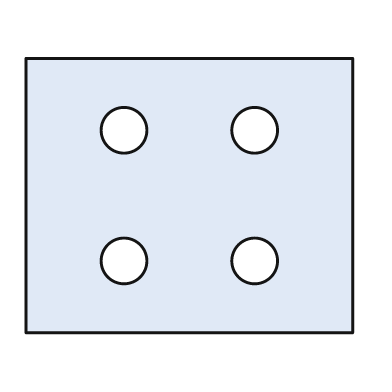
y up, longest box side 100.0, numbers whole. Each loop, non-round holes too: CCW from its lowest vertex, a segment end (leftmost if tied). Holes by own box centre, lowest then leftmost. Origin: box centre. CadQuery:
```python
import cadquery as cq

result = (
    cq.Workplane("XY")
    .moveTo(-50.0, -42.0)
    .lineTo(50.0, -42.0)
    .lineTo(50.0, 42.0)
    .lineTo(-50.0, 42.0)
    .close()
    .moveTo(-20.0, -20.0)
    .circle(7.0)
    .moveTo(20.0, -20.0)
    .circle(7.0)
    .moveTo(-20.0, 20.0)
    .circle(7.0)
    .moveTo(20.0, 20.0)
    .circle(7.0)
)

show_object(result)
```